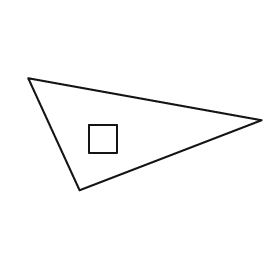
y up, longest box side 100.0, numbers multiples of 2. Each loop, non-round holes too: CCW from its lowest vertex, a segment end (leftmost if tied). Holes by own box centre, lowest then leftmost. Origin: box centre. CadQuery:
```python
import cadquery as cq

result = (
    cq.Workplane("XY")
    .moveTo(-28.0, -24.0)
    .lineTo(50.0, 6.0)
    .lineTo(-50.0, 24.0)
    .close()
    .moveTo(-24.0, -8.0)
    .lineTo(-12.0, -8.0)
    .lineTo(-12.0, 4.0)
    .lineTo(-24.0, 4.0)
    .close()
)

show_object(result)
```